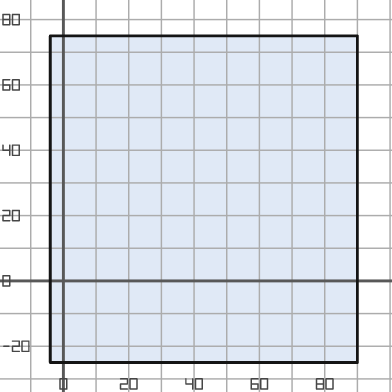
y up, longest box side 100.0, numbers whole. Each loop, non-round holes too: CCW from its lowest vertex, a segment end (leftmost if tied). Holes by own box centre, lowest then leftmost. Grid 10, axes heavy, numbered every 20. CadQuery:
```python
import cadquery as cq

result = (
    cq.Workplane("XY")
    .moveTo(-4.0, -25.0)
    .lineTo(90.0, -25.0)
    .lineTo(90.0, 75.0)
    .lineTo(-4.0, 75.0)
    .close()
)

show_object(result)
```